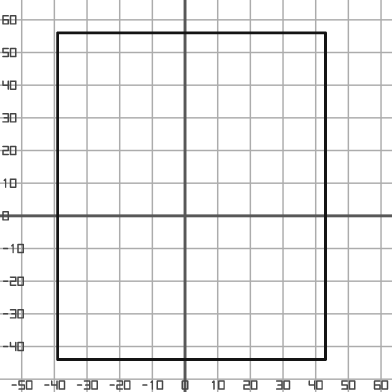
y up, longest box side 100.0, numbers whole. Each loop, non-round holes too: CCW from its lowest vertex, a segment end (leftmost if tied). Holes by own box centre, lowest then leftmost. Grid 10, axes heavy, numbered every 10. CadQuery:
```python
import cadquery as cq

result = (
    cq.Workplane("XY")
    .moveTo(-39.0, -44.0)
    .lineTo(43.0, -44.0)
    .lineTo(43.0, 56.0)
    .lineTo(-39.0, 56.0)
    .close()
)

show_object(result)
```